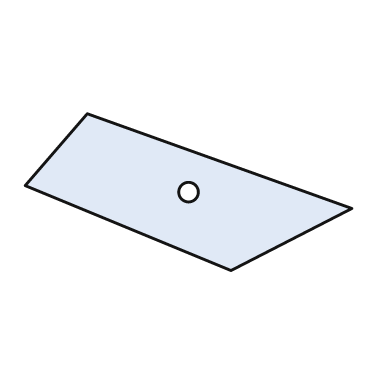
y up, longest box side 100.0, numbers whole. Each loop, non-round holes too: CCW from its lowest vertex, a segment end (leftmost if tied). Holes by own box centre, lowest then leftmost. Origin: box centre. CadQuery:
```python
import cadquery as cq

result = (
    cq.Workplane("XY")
    .moveTo(13.0, -24.0)
    .lineTo(50.0, -5.0)
    .lineTo(-31.0, 24.0)
    .lineTo(-50.0, 2.0)
    .close()
    .moveTo(0.0, 0.0)
    .circle(3.0)
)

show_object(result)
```